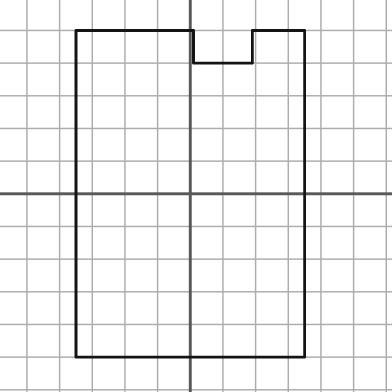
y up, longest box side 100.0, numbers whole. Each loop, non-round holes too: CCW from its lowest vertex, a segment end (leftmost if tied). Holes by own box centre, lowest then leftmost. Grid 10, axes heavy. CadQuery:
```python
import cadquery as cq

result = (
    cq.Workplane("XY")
    .moveTo(-35.0, -50.0)
    .lineTo(35.0, -50.0)
    .lineTo(35.0, 50.0)
    .lineTo(19.0, 50.0)
    .lineTo(19.0, 40.0)
    .lineTo(1.0, 40.0)
    .lineTo(1.0, 50.0)
    .lineTo(-35.0, 50.0)
    .close()
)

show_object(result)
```